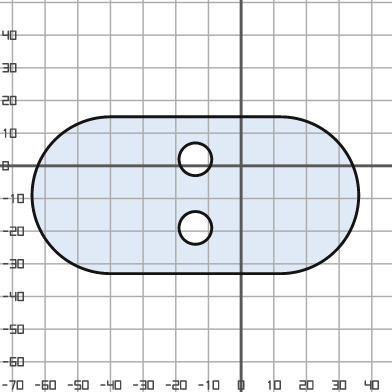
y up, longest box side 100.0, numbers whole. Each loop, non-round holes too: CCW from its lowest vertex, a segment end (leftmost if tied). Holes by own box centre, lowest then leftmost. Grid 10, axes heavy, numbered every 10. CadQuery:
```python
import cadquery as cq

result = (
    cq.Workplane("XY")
    .moveTo(-40.0, -33.0)
    .lineTo(12.0, -33.0)
    .threePointArc((36.0, -9.0), (12.0, 15.0))
    .lineTo(-40.0, 15.0)
    .threePointArc((-64.0, -9.0), (-40.0, -33.0))
    .close()
    .moveTo(-14.0, -19.0)
    .circle(5.0)
    .moveTo(-14.0, 2.0)
    .circle(5.0)
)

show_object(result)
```